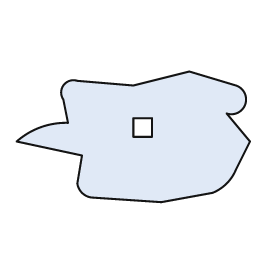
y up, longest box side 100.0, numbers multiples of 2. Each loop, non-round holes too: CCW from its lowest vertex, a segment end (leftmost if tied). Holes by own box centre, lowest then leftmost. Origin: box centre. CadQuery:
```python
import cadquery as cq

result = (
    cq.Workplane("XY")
    .moveTo(12.0, -28.0)
    .lineTo(34.0, -24.0)
    .threePointArc((40.0, -20.0), (44.0, -14.0))
    .lineTo(50.0, -2.0)
    .lineTo(40.0, 10.0)
    .threePointArc((48.0, 14.0), (44.0, 22.0))
    .lineTo(24.0, 28.0)
    .lineTo(0.0, 22.0)
    .lineTo(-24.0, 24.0)
    .threePointArc((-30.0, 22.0), (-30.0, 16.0))
    .lineTo(-28.0, 6.0)
    .threePointArc((-40.0, 4.0), (-50.0, -2.0))
    .lineTo(-22.0, -8.0)
    .lineTo(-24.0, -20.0)
    .threePointArc((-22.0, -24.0), (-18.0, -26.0))
    .close()
    .moveTo(0.0, 0.0)
    .lineTo(8.0, 0.0)
    .lineTo(8.0, 8.0)
    .lineTo(0.0, 8.0)
    .close()
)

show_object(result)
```